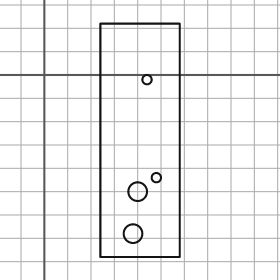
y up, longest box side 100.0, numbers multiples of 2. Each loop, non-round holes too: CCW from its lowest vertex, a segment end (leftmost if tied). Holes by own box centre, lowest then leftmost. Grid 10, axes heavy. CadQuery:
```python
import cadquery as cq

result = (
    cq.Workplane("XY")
    .moveTo(24.0, -78.0)
    .lineTo(58.0, -78.0)
    .lineTo(58.0, 22.0)
    .lineTo(24.0, 22.0)
    .close()
    .moveTo(38.0, -68.0)
    .circle(4.0)
    .moveTo(40.0, -50.0)
    .circle(4.0)
    .moveTo(48.0, -44.0)
    .circle(2.0)
    .moveTo(44.0, -2.0)
    .circle(2.0)
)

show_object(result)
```